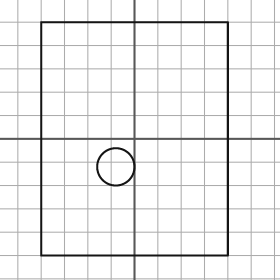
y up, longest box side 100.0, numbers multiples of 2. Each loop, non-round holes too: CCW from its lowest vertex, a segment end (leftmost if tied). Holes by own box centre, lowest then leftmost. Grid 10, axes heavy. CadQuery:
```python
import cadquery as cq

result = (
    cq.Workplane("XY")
    .moveTo(-40.0, -50.0)
    .lineTo(40.0, -50.0)
    .lineTo(40.0, 50.0)
    .lineTo(-40.0, 50.0)
    .close()
    .moveTo(-8.0, -12.0)
    .circle(8.0)
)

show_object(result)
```